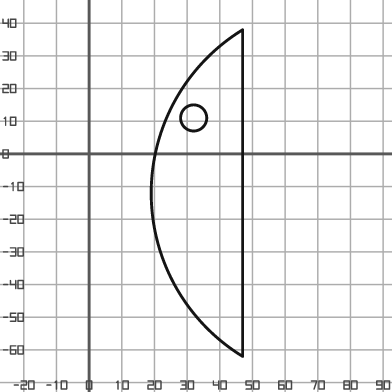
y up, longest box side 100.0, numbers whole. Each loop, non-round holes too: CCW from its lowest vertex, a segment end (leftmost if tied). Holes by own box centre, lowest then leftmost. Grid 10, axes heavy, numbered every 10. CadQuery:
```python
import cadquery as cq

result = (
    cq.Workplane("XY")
    .moveTo(47.0, -62.0)
    .lineTo(47.0, 38.0)
    .threePointArc((19.0, -12.0), (47.0, -62.0))
    .close()
    .moveTo(32.0, 11.0)
    .circle(4.0)
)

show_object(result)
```